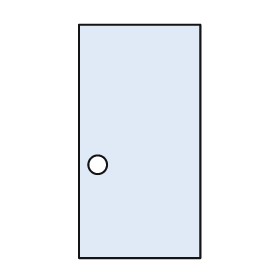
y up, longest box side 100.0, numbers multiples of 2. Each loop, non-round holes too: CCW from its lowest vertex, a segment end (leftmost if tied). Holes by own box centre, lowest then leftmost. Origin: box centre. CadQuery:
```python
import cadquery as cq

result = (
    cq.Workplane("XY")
    .moveTo(-26.0, -50.0)
    .lineTo(26.0, -50.0)
    .lineTo(26.0, 50.0)
    .lineTo(-26.0, 50.0)
    .close()
    .moveTo(-18.0, -10.0)
    .circle(4.0)
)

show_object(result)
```